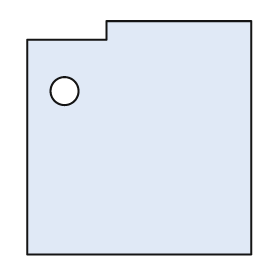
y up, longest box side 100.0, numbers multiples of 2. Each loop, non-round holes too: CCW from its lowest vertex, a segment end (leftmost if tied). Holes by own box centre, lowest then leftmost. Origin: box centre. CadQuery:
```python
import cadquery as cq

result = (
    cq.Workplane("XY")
    .moveTo(-48.0, -50.0)
    .lineTo(48.0, -50.0)
    .lineTo(48.0, 50.0)
    .lineTo(-14.0, 50.0)
    .lineTo(-14.0, 42.0)
    .lineTo(-48.0, 42.0)
    .close()
    .moveTo(-32.0, 20.0)
    .circle(6.0)
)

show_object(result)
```